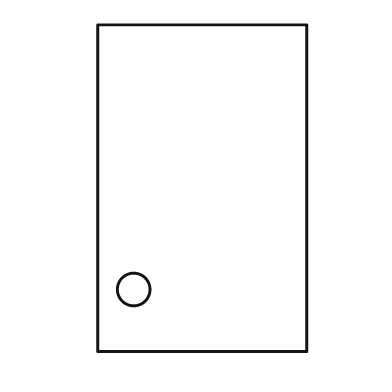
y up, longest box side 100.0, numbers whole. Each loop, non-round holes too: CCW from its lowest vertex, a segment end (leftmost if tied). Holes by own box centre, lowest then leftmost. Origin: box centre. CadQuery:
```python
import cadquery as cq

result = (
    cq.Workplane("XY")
    .moveTo(-32.0, -50.0)
    .lineTo(32.0, -50.0)
    .lineTo(32.0, 50.0)
    .lineTo(-32.0, 50.0)
    .close()
    .moveTo(-21.0, -31.0)
    .circle(5.0)
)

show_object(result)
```